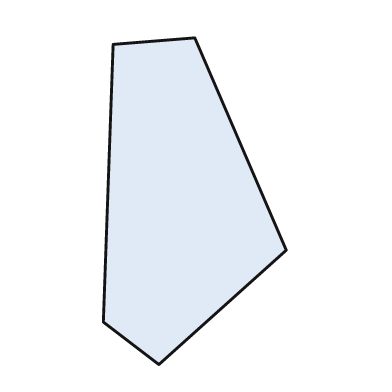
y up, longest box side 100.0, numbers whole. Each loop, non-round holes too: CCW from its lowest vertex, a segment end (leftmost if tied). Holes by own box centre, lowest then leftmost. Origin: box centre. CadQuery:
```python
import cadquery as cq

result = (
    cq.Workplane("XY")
    .moveTo(-11.0, -50.0)
    .lineTo(28.0, -15.0)
    .lineTo(0.0, 50.0)
    .lineTo(-25.0, 48.0)
    .lineTo(-28.0, -37.0)
    .close()
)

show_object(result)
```